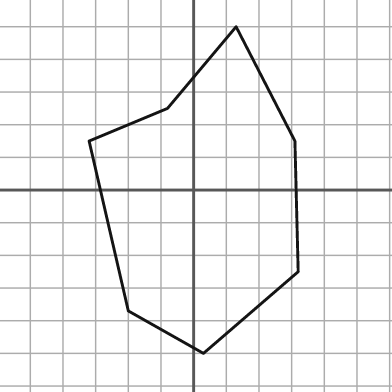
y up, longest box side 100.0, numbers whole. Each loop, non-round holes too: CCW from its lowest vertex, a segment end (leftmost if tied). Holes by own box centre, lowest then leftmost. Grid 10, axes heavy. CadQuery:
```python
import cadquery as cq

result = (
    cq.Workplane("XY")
    .moveTo(3.0, -50.0)
    .lineTo(32.0, -25.0)
    .lineTo(31.0, 15.0)
    .lineTo(13.0, 50.0)
    .lineTo(-8.0, 25.0)
    .lineTo(-32.0, 15.0)
    .lineTo(-20.0, -37.0)
    .close()
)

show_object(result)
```